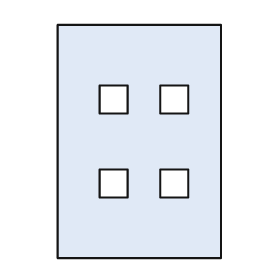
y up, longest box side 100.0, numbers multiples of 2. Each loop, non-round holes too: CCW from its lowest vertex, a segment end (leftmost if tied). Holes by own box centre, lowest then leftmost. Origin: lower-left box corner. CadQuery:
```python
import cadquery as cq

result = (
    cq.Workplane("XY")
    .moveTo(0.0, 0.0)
    .lineTo(70.0, 0.0)
    .lineTo(70.0, 100.0)
    .lineTo(0.0, 100.0)
    .close()
    .moveTo(18.0, 26.0)
    .lineTo(30.0, 26.0)
    .lineTo(30.0, 38.0)
    .lineTo(18.0, 38.0)
    .close()
    .moveTo(44.0, 26.0)
    .lineTo(56.0, 26.0)
    .lineTo(56.0, 38.0)
    .lineTo(44.0, 38.0)
    .close()
    .moveTo(18.0, 62.0)
    .lineTo(30.0, 62.0)
    .lineTo(30.0, 74.0)
    .lineTo(18.0, 74.0)
    .close()
    .moveTo(44.0, 62.0)
    .lineTo(56.0, 62.0)
    .lineTo(56.0, 74.0)
    .lineTo(44.0, 74.0)
    .close()
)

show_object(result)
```